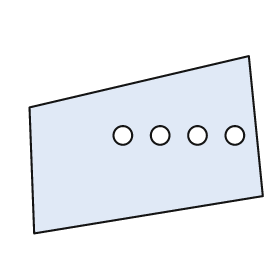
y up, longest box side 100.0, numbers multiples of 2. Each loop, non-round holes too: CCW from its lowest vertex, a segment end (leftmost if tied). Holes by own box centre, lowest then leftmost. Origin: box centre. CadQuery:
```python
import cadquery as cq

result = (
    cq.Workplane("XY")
    .moveTo(-48.0, -38.0)
    .lineTo(50.0, -22.0)
    .lineTo(44.0, 38.0)
    .lineTo(-50.0, 16.0)
    .close()
    .moveTo(-10.0, 4.0)
    .circle(4.0)
    .moveTo(6.0, 4.0)
    .circle(4.0)
    .moveTo(22.0, 4.0)
    .circle(4.0)
    .moveTo(38.0, 4.0)
    .circle(4.0)
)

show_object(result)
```